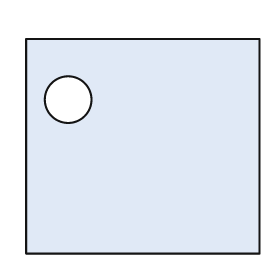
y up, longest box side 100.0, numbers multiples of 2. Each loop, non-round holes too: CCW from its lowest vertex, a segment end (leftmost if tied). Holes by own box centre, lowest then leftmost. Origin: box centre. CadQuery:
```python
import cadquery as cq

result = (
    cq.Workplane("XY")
    .moveTo(-50.0, -46.0)
    .lineTo(50.0, -46.0)
    .lineTo(50.0, 46.0)
    .lineTo(-50.0, 46.0)
    .close()
    .moveTo(-32.0, 20.0)
    .circle(10.0)
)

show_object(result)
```